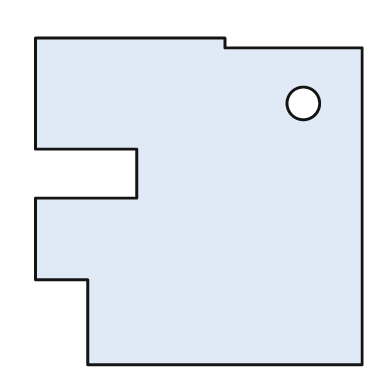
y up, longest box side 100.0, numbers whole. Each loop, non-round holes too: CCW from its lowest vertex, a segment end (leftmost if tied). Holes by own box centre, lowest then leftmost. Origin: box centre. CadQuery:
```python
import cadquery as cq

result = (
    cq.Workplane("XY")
    .moveTo(-34.0, -50.0)
    .lineTo(50.0, -50.0)
    .lineTo(50.0, 47.0)
    .lineTo(8.0, 47.0)
    .lineTo(8.0, 50.0)
    .lineTo(-50.0, 50.0)
    .lineTo(-50.0, 16.0)
    .lineTo(-19.0, 16.0)
    .lineTo(-19.0, 1.0)
    .lineTo(-50.0, 1.0)
    .lineTo(-50.0, -24.0)
    .lineTo(-34.0, -24.0)
    .close()
    .moveTo(32.0, 30.0)
    .circle(5.0)
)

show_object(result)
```